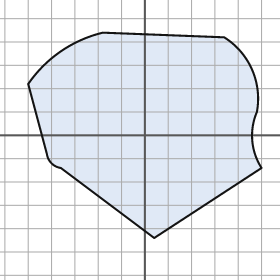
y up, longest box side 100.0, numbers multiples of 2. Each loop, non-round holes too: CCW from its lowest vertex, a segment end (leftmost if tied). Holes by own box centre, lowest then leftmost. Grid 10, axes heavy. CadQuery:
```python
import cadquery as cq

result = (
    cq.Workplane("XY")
    .moveTo(4.0, -44.0)
    .lineTo(50.0, -14.0)
    .threePointArc((46.0, -2.0), (48.0, 10.0))
    .threePointArc((46.0, 28.0), (34.0, 42.0))
    .lineTo(-18.0, 44.0)
    .threePointArc((-36.0, 36.0), (-50.0, 22.0))
    .lineTo(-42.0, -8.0)
    .threePointArc((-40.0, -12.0), (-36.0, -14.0))
    .close()
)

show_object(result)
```